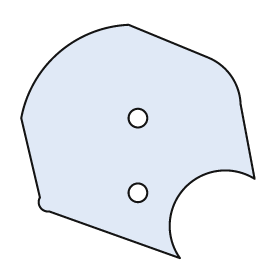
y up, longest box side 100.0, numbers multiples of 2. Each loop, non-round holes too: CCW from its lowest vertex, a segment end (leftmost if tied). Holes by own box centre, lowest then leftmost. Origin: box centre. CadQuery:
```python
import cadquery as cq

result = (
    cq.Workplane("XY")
    .moveTo(18.0, -50.0)
    .threePointArc((20.0, -20.0), (50.0, -16.0))
    .lineTo(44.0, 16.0)
    .threePointArc((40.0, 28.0), (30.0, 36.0))
    .lineTo(-4.0, 50.0)
    .threePointArc((-34.0, 38.0), (-50.0, 10.0))
    .lineTo(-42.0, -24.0)
    .threePointArc((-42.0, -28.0), (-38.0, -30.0))
    .close()
    .moveTo(0.0, -22.0)
    .circle(4.0)
    .moveTo(0.0, 10.0)
    .circle(4.0)
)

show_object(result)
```